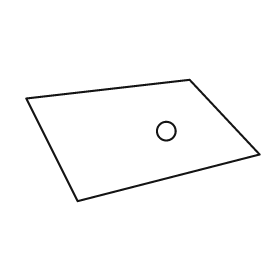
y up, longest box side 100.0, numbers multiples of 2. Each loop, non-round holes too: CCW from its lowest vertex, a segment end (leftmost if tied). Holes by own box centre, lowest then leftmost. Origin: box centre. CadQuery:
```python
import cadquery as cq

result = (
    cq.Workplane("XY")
    .moveTo(-28.0, -26.0)
    .lineTo(50.0, -6.0)
    .lineTo(20.0, 26.0)
    .lineTo(-50.0, 18.0)
    .close()
    .moveTo(10.0, 4.0)
    .circle(4.0)
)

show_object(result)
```